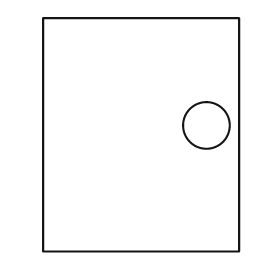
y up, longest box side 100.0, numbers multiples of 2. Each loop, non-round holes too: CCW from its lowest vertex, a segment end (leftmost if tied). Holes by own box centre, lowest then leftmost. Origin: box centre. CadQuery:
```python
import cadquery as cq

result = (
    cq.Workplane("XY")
    .moveTo(-42.0, -50.0)
    .lineTo(42.0, -50.0)
    .lineTo(42.0, 50.0)
    .lineTo(-42.0, 50.0)
    .close()
    .moveTo(28.0, 4.0)
    .circle(10.0)
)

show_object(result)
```